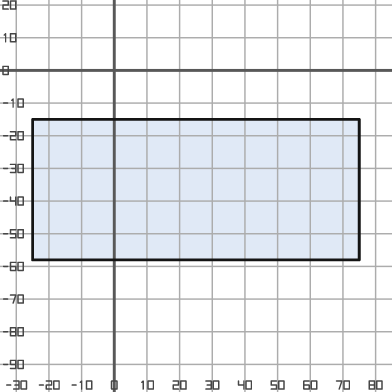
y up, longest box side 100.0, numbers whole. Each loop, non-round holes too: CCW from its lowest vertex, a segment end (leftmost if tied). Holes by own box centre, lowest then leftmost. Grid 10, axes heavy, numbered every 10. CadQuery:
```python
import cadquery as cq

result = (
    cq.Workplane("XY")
    .moveTo(-25.0, -58.0)
    .lineTo(75.0, -58.0)
    .lineTo(75.0, -15.0)
    .lineTo(-25.0, -15.0)
    .close()
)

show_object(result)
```